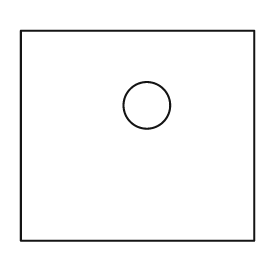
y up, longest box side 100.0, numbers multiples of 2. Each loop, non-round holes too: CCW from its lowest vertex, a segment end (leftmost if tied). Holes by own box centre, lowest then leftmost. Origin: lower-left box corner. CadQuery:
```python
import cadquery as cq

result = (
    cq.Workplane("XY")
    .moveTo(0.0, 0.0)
    .lineTo(100.0, 0.0)
    .lineTo(100.0, 90.0)
    .lineTo(0.0, 90.0)
    .close()
    .moveTo(54.0, 58.0)
    .circle(10.0)
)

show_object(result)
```